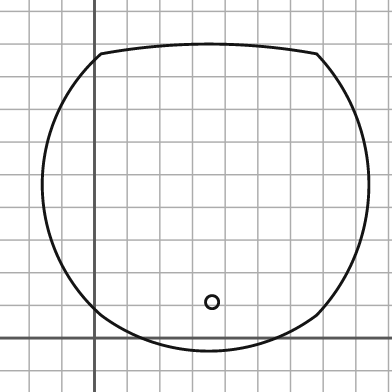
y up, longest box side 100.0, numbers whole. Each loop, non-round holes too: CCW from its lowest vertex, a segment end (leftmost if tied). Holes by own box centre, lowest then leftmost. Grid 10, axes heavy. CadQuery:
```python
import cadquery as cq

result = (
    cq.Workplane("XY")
    .moveTo(2.0, 7.0)
    .threePointArc((35.0, -4.0), (68.0, 7.0))
    .threePointArc((84.0, 47.0), (68.0, 87.0))
    .threePointArc((35.0, 90.0), (2.0, 87.0))
    .threePointArc((-16.0, 47.0), (2.0, 7.0))
    .close()
    .moveTo(36.0, 11.0)
    .circle(2.0)
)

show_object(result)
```